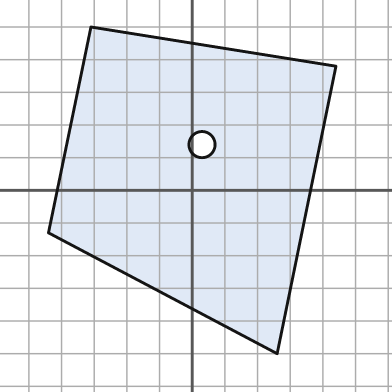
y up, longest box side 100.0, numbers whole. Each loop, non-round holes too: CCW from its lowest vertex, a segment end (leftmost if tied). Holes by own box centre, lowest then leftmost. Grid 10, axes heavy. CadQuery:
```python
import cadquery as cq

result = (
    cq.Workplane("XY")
    .moveTo(26.0, -50.0)
    .lineTo(44.0, 38.0)
    .lineTo(-31.0, 50.0)
    .lineTo(-44.0, -13.0)
    .close()
    .moveTo(3.0, 14.0)
    .circle(4.0)
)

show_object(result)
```